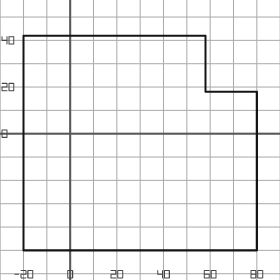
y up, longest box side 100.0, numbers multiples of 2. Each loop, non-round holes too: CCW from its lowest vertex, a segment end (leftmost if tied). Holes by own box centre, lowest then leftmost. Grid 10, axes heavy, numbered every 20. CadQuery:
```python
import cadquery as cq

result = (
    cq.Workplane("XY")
    .moveTo(-20.0, -50.0)
    .lineTo(80.0, -50.0)
    .lineTo(80.0, 18.0)
    .lineTo(58.0, 18.0)
    .lineTo(58.0, 42.0)
    .lineTo(-20.0, 42.0)
    .close()
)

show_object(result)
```